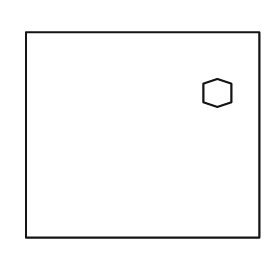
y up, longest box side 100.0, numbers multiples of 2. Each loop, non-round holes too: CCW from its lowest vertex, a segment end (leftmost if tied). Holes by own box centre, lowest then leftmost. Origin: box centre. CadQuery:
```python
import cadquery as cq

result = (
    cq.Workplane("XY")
    .moveTo(-50.0, -44.0)
    .lineTo(50.0, -44.0)
    .lineTo(50.0, 44.0)
    .lineTo(-50.0, 44.0)
    .close()
    .moveTo(32.0, 12.0)
    .lineTo(38.0, 14.0)
    .lineTo(38.0, 22.0)
    .lineTo(32.0, 24.0)
    .lineTo(26.0, 22.0)
    .lineTo(26.0, 14.0)
    .close()
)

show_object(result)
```